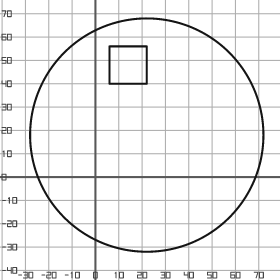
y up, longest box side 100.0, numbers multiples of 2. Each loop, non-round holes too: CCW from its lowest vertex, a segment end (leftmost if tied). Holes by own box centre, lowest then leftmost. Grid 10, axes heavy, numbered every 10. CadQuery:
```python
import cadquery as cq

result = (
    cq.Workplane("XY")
    .moveTo(22.0, 18.0)
    .circle(50.0)
    .moveTo(6.0, 40.0)
    .lineTo(22.0, 40.0)
    .lineTo(22.0, 56.0)
    .lineTo(6.0, 56.0)
    .close()
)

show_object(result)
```